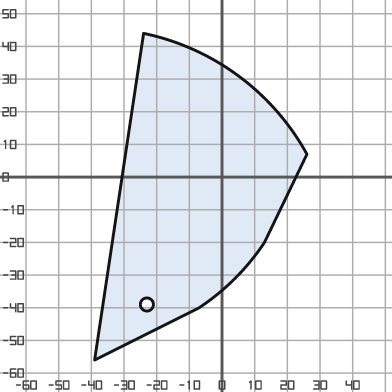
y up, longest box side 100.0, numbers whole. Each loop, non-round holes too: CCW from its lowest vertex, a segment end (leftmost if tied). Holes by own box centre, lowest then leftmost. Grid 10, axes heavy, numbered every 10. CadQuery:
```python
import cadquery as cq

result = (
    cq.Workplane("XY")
    .moveTo(-39.0, -56.0)
    .lineTo(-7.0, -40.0)
    .threePointArc((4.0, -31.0), (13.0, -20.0))
    .lineTo(26.0, 7.0)
    .threePointArc((5.0, 31.0), (-24.0, 44.0))
    .close()
    .moveTo(-23.0, -39.0)
    .circle(2.0)
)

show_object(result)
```